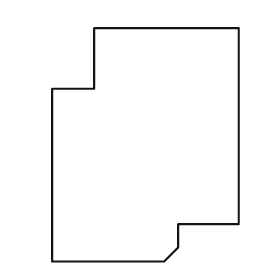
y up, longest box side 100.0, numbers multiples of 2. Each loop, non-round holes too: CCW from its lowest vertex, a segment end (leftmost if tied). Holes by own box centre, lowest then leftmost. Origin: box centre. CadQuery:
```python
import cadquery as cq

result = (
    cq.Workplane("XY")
    .moveTo(-40.0, -50.0)
    .lineTo(8.0, -50.0)
    .lineTo(14.0, -44.0)
    .lineTo(14.0, -34.0)
    .lineTo(40.0, -34.0)
    .lineTo(40.0, 50.0)
    .lineTo(-22.0, 50.0)
    .lineTo(-22.0, 24.0)
    .lineTo(-40.0, 24.0)
    .close()
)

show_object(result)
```